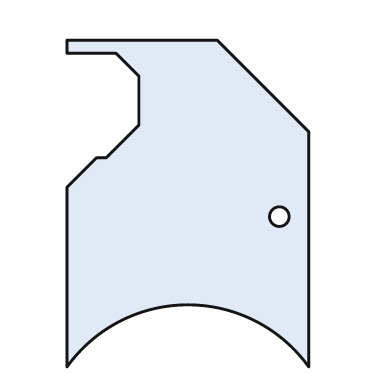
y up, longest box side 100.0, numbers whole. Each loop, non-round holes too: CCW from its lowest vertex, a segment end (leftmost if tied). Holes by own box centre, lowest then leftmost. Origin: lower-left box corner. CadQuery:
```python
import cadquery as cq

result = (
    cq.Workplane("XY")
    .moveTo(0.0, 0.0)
    .threePointArc((37.0, 19.0), (74.0, 0.0))
    .lineTo(74.0, 72.0)
    .lineTo(46.0, 100.0)
    .lineTo(0.0, 100.0)
    .lineTo(0.0, 96.0)
    .lineTo(15.0, 96.0)
    .lineTo(22.0, 89.0)
    .lineTo(22.0, 74.0)
    .lineTo(12.0, 64.0)
    .lineTo(9.0, 64.0)
    .lineTo(0.0, 55.0)
    .close()
    .moveTo(65.0, 46.0)
    .circle(3.0)
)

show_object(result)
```